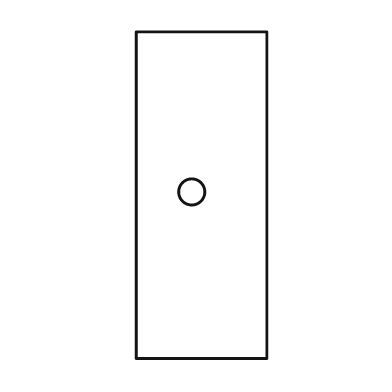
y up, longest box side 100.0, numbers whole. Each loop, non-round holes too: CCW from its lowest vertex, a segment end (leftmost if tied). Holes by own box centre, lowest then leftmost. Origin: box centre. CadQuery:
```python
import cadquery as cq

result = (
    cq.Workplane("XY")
    .moveTo(-20.0, -50.0)
    .lineTo(20.0, -50.0)
    .lineTo(20.0, 50.0)
    .lineTo(-20.0, 50.0)
    .close()
    .moveTo(-3.0, 1.0)
    .circle(4.0)
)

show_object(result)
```